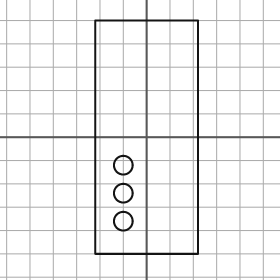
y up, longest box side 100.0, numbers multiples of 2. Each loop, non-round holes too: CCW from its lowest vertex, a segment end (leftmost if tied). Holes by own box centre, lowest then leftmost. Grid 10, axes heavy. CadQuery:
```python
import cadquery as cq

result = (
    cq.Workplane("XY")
    .moveTo(-22.0, -50.0)
    .lineTo(22.0, -50.0)
    .lineTo(22.0, 50.0)
    .lineTo(-22.0, 50.0)
    .close()
    .moveTo(-10.0, -36.0)
    .circle(4.0)
    .moveTo(-10.0, -24.0)
    .circle(4.0)
    .moveTo(-10.0, -12.0)
    .circle(4.0)
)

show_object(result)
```